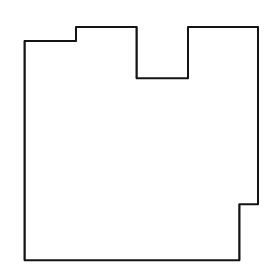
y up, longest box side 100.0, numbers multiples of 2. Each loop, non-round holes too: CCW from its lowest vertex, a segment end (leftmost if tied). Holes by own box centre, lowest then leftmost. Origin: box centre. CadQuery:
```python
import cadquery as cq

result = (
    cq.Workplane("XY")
    .moveTo(-50.0, -50.0)
    .lineTo(42.0, -50.0)
    .lineTo(42.0, -26.0)
    .lineTo(50.0, -26.0)
    .lineTo(50.0, 50.0)
    .lineTo(20.0, 50.0)
    .lineTo(20.0, 28.0)
    .lineTo(-2.0, 28.0)
    .lineTo(-2.0, 50.0)
    .lineTo(-28.0, 50.0)
    .lineTo(-28.0, 44.0)
    .lineTo(-50.0, 44.0)
    .close()
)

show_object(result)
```